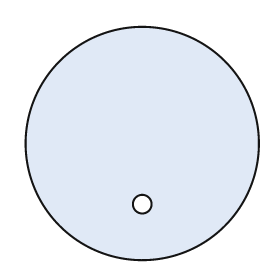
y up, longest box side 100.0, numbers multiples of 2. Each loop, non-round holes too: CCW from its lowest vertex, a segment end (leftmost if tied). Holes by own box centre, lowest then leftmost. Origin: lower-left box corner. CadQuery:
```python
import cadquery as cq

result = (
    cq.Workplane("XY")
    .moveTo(50.0, 50.0)
    .circle(50.0)
    .moveTo(50.0, 24.0)
    .circle(4.0)
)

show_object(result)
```